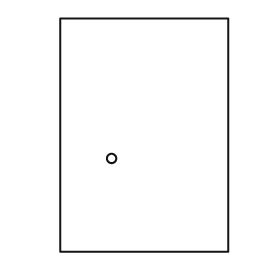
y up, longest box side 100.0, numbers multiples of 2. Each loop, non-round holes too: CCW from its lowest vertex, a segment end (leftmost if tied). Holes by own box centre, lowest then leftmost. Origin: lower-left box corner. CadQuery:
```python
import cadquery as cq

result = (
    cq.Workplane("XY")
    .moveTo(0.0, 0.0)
    .lineTo(72.0, 0.0)
    .lineTo(72.0, 100.0)
    .lineTo(0.0, 100.0)
    .close()
    .moveTo(22.0, 40.0)
    .circle(2.0)
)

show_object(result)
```